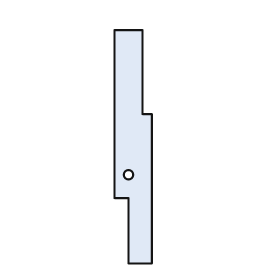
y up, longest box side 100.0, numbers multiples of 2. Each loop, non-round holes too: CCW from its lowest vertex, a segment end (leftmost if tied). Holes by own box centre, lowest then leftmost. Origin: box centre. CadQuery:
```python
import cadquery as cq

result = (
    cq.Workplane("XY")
    .moveTo(-2.0, -50.0)
    .lineTo(8.0, -50.0)
    .lineTo(8.0, 14.0)
    .lineTo(4.0, 14.0)
    .lineTo(4.0, 50.0)
    .lineTo(-8.0, 50.0)
    .lineTo(-8.0, -22.0)
    .lineTo(-2.0, -22.0)
    .close()
    .moveTo(-2.0, -12.0)
    .circle(2.0)
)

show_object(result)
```